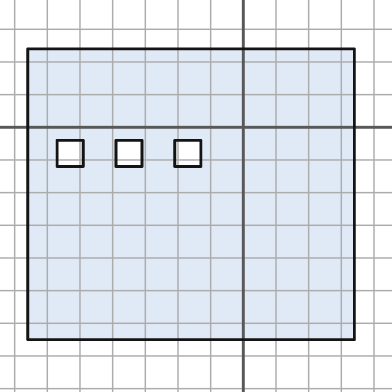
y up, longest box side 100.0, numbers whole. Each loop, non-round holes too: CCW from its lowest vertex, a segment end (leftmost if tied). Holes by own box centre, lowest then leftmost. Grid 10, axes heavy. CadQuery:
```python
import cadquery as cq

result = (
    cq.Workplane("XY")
    .moveTo(-66.0, -65.0)
    .lineTo(34.0, -65.0)
    .lineTo(34.0, 24.0)
    .lineTo(-66.0, 24.0)
    .close()
    .moveTo(-57.0, -12.0)
    .lineTo(-49.0, -12.0)
    .lineTo(-49.0, -4.0)
    .lineTo(-57.0, -4.0)
    .close()
    .moveTo(-39.0, -12.0)
    .lineTo(-31.0, -12.0)
    .lineTo(-31.0, -4.0)
    .lineTo(-39.0, -4.0)
    .close()
    .moveTo(-21.0, -12.0)
    .lineTo(-13.0, -12.0)
    .lineTo(-13.0, -4.0)
    .lineTo(-21.0, -4.0)
    .close()
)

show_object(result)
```